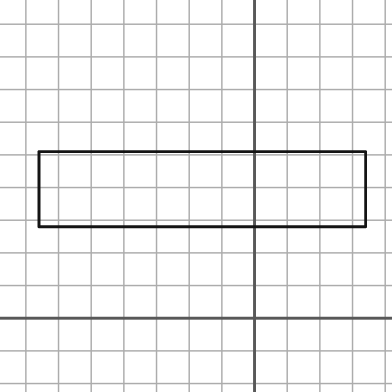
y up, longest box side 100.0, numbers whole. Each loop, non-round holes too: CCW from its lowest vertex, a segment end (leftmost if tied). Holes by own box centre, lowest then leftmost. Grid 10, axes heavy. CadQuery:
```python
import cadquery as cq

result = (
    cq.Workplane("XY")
    .moveTo(-66.0, 28.0)
    .lineTo(34.0, 28.0)
    .lineTo(34.0, 51.0)
    .lineTo(-66.0, 51.0)
    .close()
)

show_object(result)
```